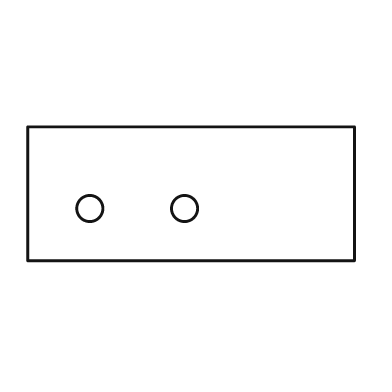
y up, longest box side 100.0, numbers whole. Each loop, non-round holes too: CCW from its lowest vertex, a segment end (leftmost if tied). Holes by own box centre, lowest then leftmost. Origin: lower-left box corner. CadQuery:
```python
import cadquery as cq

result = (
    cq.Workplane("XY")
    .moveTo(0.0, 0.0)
    .lineTo(100.0, 0.0)
    .lineTo(100.0, 41.0)
    .lineTo(0.0, 41.0)
    .close()
    .moveTo(19.0, 16.0)
    .circle(4.0)
    .moveTo(48.0, 16.0)
    .circle(4.0)
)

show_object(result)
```